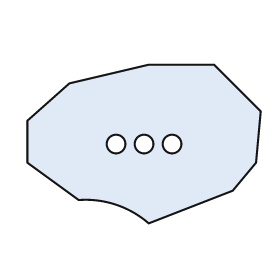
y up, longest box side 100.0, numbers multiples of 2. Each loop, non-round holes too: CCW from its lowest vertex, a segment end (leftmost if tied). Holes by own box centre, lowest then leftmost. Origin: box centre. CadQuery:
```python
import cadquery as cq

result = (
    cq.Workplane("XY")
    .moveTo(2.0, -34.0)
    .lineTo(38.0, -20.0)
    .lineTo(48.0, -8.0)
    .lineTo(50.0, 14.0)
    .lineTo(30.0, 34.0)
    .lineTo(2.0, 34.0)
    .lineTo(-32.0, 26.0)
    .lineTo(-50.0, 10.0)
    .lineTo(-50.0, -8.0)
    .lineTo(-28.0, -24.0)
    .threePointArc((-12.0, -26.0), (2.0, -34.0))
    .close()
    .moveTo(-12.0, 0.0)
    .circle(4.0)
    .moveTo(0.0, 0.0)
    .circle(4.0)
    .moveTo(12.0, 0.0)
    .circle(4.0)
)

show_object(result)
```